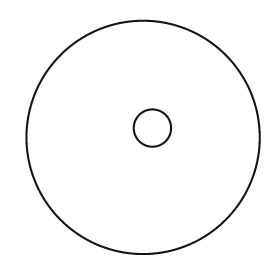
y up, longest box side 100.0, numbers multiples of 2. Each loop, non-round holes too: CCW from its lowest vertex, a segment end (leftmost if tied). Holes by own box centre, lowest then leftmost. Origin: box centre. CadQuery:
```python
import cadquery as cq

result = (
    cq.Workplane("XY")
    .moveTo(0.0, 0.0)
    .circle(50.0)
    .moveTo(4.0, 4.0)
    .circle(8.0)
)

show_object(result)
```